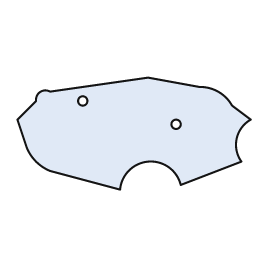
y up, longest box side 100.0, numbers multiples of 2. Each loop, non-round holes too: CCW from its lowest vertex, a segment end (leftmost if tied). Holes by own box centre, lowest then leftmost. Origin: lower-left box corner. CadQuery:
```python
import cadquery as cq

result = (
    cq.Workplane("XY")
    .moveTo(44.0, 0.0)
    .threePointArc((56.0, 12.0), (70.0, 2.0))
    .lineTo(96.0, 12.0)
    .threePointArc((94.0, 22.0), (100.0, 30.0))
    .lineTo(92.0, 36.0)
    .threePointArc((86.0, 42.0), (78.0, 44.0))
    .lineTo(56.0, 48.0)
    .lineTo(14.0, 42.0)
    .threePointArc((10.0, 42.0), (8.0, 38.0))
    .lineTo(0.0, 30.0)
    .lineTo(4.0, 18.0)
    .threePointArc((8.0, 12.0), (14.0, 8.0))
    .close()
    .moveTo(68.0, 28.0)
    .circle(2.0)
    .moveTo(28.0, 38.0)
    .circle(2.0)
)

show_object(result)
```